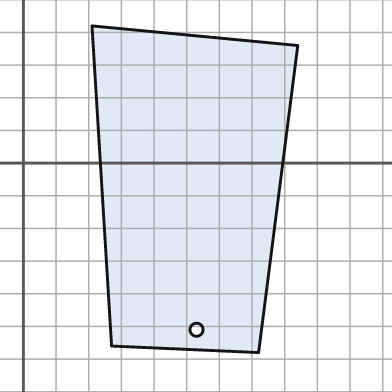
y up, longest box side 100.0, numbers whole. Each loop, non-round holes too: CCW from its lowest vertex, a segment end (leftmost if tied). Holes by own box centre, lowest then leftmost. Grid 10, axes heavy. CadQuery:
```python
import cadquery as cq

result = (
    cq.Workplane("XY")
    .moveTo(72.0, -58.0)
    .lineTo(84.0, 36.0)
    .lineTo(21.0, 42.0)
    .lineTo(27.0, -56.0)
    .close()
    .moveTo(53.0, -51.0)
    .circle(2.0)
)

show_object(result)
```